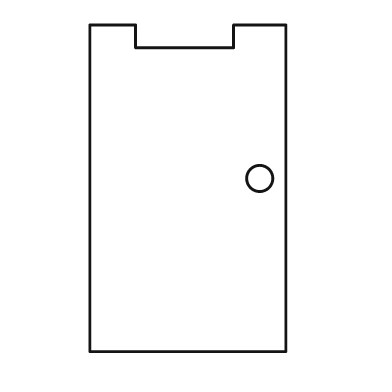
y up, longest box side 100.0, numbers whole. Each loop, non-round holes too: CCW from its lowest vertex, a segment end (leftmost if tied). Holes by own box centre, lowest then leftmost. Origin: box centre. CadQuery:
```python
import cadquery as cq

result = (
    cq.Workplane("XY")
    .moveTo(-30.0, -50.0)
    .lineTo(30.0, -50.0)
    .lineTo(30.0, 50.0)
    .lineTo(14.0, 50.0)
    .lineTo(14.0, 43.0)
    .lineTo(-16.0, 43.0)
    .lineTo(-16.0, 50.0)
    .lineTo(-30.0, 50.0)
    .close()
    .moveTo(22.0, 3.0)
    .circle(4.0)
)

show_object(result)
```